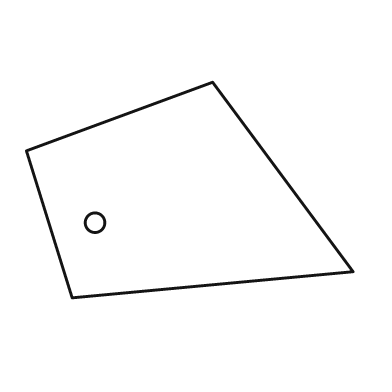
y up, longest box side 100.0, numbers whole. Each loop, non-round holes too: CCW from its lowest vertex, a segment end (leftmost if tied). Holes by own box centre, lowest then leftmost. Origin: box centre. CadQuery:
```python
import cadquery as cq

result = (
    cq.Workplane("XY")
    .moveTo(-36.0, -33.0)
    .lineTo(50.0, -25.0)
    .lineTo(7.0, 33.0)
    .lineTo(-50.0, 12.0)
    .close()
    .moveTo(-29.0, -10.0)
    .circle(3.0)
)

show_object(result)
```